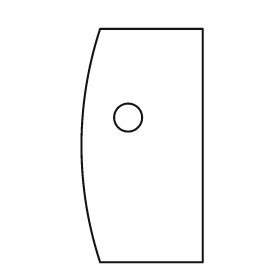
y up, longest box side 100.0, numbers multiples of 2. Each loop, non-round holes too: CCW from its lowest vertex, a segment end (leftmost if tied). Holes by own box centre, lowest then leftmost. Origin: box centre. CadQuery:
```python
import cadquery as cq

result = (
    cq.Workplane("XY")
    .moveTo(-18.0, -50.0)
    .lineTo(26.0, -50.0)
    .lineTo(26.0, 50.0)
    .lineTo(-18.0, 50.0)
    .threePointArc((-26.0, 0.0), (-18.0, -50.0))
    .close()
    .moveTo(-6.0, 12.0)
    .circle(6.0)
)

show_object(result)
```